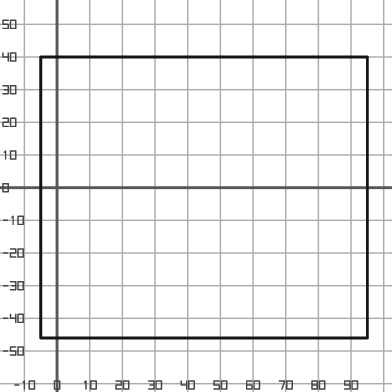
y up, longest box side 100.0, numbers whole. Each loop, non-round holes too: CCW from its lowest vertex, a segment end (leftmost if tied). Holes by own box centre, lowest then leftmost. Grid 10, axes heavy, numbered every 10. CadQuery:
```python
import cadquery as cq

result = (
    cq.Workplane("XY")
    .moveTo(-5.0, -46.0)
    .lineTo(95.0, -46.0)
    .lineTo(95.0, 40.0)
    .lineTo(-5.0, 40.0)
    .close()
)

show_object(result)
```